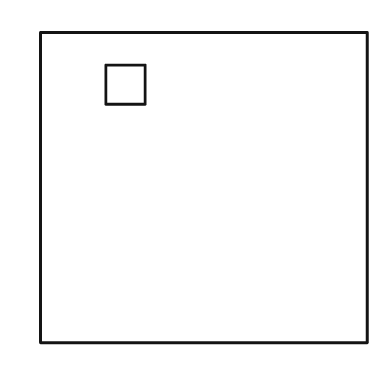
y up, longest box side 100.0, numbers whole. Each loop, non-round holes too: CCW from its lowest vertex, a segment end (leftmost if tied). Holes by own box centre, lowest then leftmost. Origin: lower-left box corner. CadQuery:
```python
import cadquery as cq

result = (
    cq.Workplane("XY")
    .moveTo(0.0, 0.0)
    .lineTo(100.0, 0.0)
    .lineTo(100.0, 95.0)
    .lineTo(0.0, 95.0)
    .close()
    .moveTo(20.0, 73.0)
    .lineTo(32.0, 73.0)
    .lineTo(32.0, 85.0)
    .lineTo(20.0, 85.0)
    .close()
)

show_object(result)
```